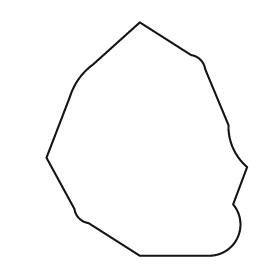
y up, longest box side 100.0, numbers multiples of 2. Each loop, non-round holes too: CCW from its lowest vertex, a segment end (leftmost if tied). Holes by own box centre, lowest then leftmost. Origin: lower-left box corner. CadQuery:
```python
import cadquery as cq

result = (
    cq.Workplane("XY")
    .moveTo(40.0, 0.0)
    .lineTo(70.0, 0.0)
    .threePointArc((82.0, 8.0), (80.0, 22.0))
    .lineTo(86.0, 38.0)
    .threePointArc((80.0, 46.0), (78.0, 56.0))
    .lineTo(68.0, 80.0)
    .threePointArc((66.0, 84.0), (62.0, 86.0))
    .lineTo(40.0, 100.0)
    .lineTo(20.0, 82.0)
    .threePointArc((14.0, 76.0), (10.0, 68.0))
    .lineTo(0.0, 42.0)
    .lineTo(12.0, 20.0)
    .threePointArc((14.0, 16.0), (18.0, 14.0))
    .close()
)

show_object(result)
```